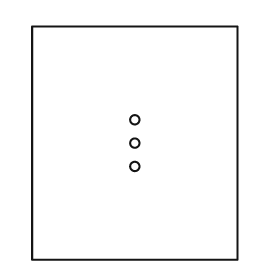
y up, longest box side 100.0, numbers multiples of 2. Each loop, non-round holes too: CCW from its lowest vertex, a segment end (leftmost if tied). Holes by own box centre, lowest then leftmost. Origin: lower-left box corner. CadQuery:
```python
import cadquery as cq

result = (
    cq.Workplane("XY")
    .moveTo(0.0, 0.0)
    .lineTo(88.0, 0.0)
    .lineTo(88.0, 100.0)
    .lineTo(0.0, 100.0)
    .close()
    .moveTo(44.0, 40.0)
    .circle(2.0)
    .moveTo(44.0, 50.0)
    .circle(2.0)
    .moveTo(44.0, 60.0)
    .circle(2.0)
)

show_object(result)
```